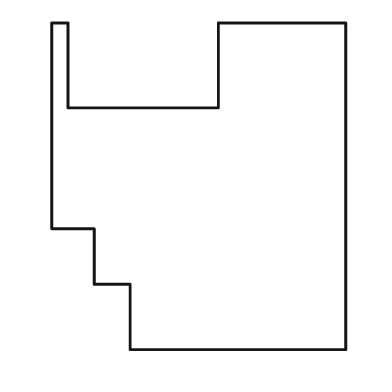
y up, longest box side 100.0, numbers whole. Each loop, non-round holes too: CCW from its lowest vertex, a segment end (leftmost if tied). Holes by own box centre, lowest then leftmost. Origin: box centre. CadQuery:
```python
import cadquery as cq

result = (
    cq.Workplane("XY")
    .moveTo(-21.0, -50.0)
    .lineTo(45.0, -50.0)
    .lineTo(45.0, 50.0)
    .lineTo(6.0, 50.0)
    .lineTo(6.0, 24.0)
    .lineTo(-40.0, 24.0)
    .lineTo(-40.0, 50.0)
    .lineTo(-45.0, 50.0)
    .lineTo(-45.0, -13.0)
    .lineTo(-32.0, -13.0)
    .lineTo(-32.0, -30.0)
    .lineTo(-21.0, -30.0)
    .close()
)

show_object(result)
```